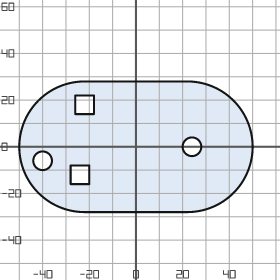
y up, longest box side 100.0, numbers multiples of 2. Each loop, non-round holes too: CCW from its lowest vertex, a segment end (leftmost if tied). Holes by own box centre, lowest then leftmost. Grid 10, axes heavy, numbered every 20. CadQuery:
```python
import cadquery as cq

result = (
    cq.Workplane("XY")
    .moveTo(-22.0, -28.0)
    .lineTo(22.0, -28.0)
    .threePointArc((50.0, 0.0), (22.0, 28.0))
    .lineTo(-22.0, 28.0)
    .threePointArc((-50.0, 0.0), (-22.0, -28.0))
    .close()
    .moveTo(-28.0, -16.0)
    .lineTo(-20.0, -16.0)
    .lineTo(-20.0, -8.0)
    .lineTo(-28.0, -8.0)
    .close()
    .moveTo(-40.0, -6.0)
    .circle(4.0)
    .moveTo(24.0, 0.0)
    .circle(4.0)
    .moveTo(-26.0, 14.0)
    .lineTo(-18.0, 14.0)
    .lineTo(-18.0, 22.0)
    .lineTo(-26.0, 22.0)
    .close()
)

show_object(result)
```